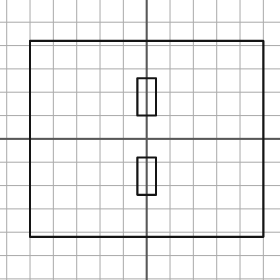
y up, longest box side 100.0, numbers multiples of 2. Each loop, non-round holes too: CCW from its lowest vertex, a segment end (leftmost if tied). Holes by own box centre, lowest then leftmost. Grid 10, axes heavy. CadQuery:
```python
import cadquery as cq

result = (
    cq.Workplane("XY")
    .moveTo(-50.0, -42.0)
    .lineTo(50.0, -42.0)
    .lineTo(50.0, 42.0)
    .lineTo(-50.0, 42.0)
    .close()
    .moveTo(-4.0, -24.0)
    .lineTo(4.0, -24.0)
    .lineTo(4.0, -8.0)
    .lineTo(-4.0, -8.0)
    .close()
    .moveTo(-4.0, 10.0)
    .lineTo(4.0, 10.0)
    .lineTo(4.0, 26.0)
    .lineTo(-4.0, 26.0)
    .close()
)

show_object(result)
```